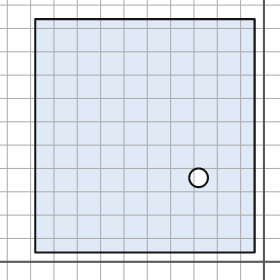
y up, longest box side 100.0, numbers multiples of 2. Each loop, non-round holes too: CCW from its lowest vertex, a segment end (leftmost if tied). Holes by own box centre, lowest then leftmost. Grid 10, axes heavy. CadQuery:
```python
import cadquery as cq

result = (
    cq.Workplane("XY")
    .moveTo(-98.0, 4.0)
    .lineTo(-4.0, 4.0)
    .lineTo(-4.0, 104.0)
    .lineTo(-98.0, 104.0)
    .close()
    .moveTo(-28.0, 36.0)
    .circle(4.0)
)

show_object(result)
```